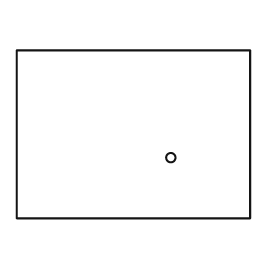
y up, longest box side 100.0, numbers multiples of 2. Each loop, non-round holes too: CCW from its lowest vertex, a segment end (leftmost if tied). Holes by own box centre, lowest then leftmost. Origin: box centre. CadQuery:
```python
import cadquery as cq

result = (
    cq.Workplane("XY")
    .moveTo(-50.0, -36.0)
    .lineTo(50.0, -36.0)
    .lineTo(50.0, 36.0)
    .lineTo(-50.0, 36.0)
    .close()
    .moveTo(16.0, -10.0)
    .circle(2.0)
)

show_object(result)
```